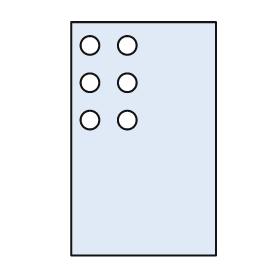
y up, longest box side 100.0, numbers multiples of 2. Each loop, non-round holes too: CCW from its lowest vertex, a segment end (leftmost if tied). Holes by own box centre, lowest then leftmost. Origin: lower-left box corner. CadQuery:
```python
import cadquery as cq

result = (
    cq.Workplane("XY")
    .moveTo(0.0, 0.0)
    .lineTo(62.0, 0.0)
    .lineTo(62.0, 100.0)
    .lineTo(0.0, 100.0)
    .close()
    .moveTo(8.0, 58.0)
    .circle(4.0)
    .moveTo(24.0, 58.0)
    .circle(4.0)
    .moveTo(8.0, 74.0)
    .circle(4.0)
    .moveTo(24.0, 74.0)
    .circle(4.0)
    .moveTo(8.0, 90.0)
    .circle(4.0)
    .moveTo(24.0, 90.0)
    .circle(4.0)
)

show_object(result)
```